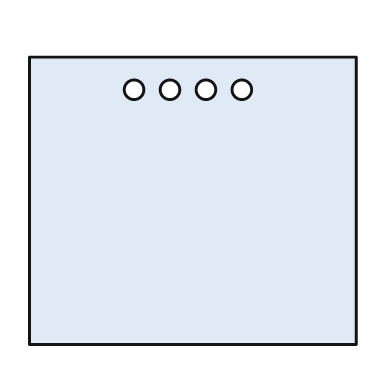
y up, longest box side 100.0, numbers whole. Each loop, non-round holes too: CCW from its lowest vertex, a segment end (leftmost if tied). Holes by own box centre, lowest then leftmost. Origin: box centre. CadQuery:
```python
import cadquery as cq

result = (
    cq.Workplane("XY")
    .moveTo(-50.0, -44.0)
    .lineTo(50.0, -44.0)
    .lineTo(50.0, 44.0)
    .lineTo(-50.0, 44.0)
    .close()
    .moveTo(-18.0, 34.0)
    .circle(3.0)
    .moveTo(-7.0, 34.0)
    .circle(3.0)
    .moveTo(4.0, 34.0)
    .circle(3.0)
    .moveTo(15.0, 34.0)
    .circle(3.0)
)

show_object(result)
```